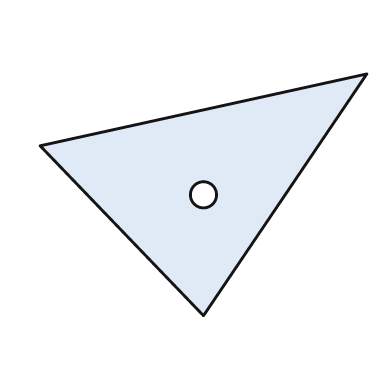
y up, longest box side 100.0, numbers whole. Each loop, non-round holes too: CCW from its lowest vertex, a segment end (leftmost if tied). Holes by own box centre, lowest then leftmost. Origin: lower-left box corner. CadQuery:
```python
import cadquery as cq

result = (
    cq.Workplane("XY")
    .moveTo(50.0, 0.0)
    .lineTo(100.0, 74.0)
    .lineTo(0.0, 52.0)
    .close()
    .moveTo(50.0, 37.0)
    .circle(4.0)
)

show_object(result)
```